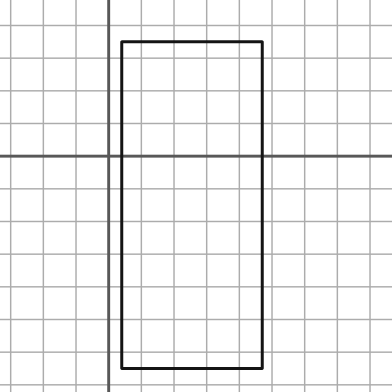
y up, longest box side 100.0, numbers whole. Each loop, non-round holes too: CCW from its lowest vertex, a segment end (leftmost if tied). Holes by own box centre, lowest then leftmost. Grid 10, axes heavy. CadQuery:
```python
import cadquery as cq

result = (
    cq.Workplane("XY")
    .moveTo(4.0, -65.0)
    .lineTo(47.0, -65.0)
    .lineTo(47.0, 35.0)
    .lineTo(4.0, 35.0)
    .close()
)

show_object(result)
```